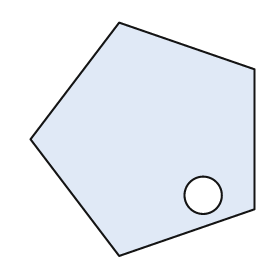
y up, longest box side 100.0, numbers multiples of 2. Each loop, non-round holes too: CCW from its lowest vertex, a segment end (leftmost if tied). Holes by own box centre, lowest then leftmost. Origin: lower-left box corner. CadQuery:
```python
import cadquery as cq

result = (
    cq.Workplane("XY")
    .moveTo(38.0, 0.0)
    .lineTo(96.0, 20.0)
    .lineTo(96.0, 80.0)
    .lineTo(38.0, 100.0)
    .lineTo(0.0, 50.0)
    .close()
    .moveTo(74.0, 26.0)
    .circle(8.0)
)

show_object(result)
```